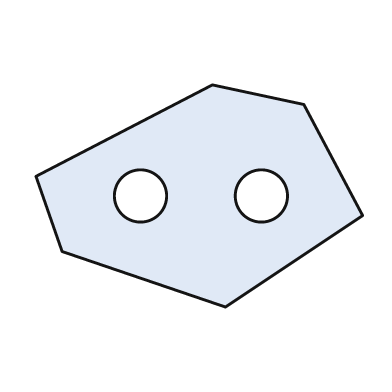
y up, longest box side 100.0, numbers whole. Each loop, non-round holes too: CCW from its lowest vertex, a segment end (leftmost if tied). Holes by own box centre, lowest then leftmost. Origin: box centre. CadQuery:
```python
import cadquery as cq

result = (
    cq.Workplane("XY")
    .moveTo(8.0, -34.0)
    .lineTo(50.0, -6.0)
    .lineTo(32.0, 28.0)
    .lineTo(4.0, 34.0)
    .lineTo(-50.0, 6.0)
    .lineTo(-42.0, -17.0)
    .close()
    .moveTo(-18.0, 0.0)
    .circle(8.0)
    .moveTo(19.0, 0.0)
    .circle(8.0)
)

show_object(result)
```